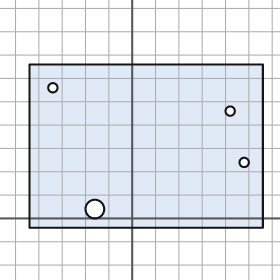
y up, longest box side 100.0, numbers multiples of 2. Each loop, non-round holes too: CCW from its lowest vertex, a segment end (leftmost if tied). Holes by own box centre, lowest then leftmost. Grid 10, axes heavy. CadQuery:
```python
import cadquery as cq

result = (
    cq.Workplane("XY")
    .moveTo(-44.0, -4.0)
    .lineTo(56.0, -4.0)
    .lineTo(56.0, 66.0)
    .lineTo(-44.0, 66.0)
    .close()
    .moveTo(-16.0, 4.0)
    .circle(4.0)
    .moveTo(48.0, 24.0)
    .circle(2.0)
    .moveTo(42.0, 46.0)
    .circle(2.0)
    .moveTo(-34.0, 56.0)
    .circle(2.0)
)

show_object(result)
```